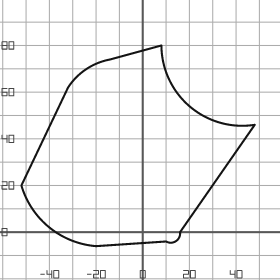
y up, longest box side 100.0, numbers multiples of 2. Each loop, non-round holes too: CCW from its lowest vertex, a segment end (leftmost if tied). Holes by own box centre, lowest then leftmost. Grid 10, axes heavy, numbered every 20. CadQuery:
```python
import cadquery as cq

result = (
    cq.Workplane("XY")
    .moveTo(-20.0, -6.0)
    .lineTo(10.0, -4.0)
    .threePointArc((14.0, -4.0), (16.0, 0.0))
    .lineTo(48.0, 46.0)
    .threePointArc((20.0, 54.0), (8.0, 80.0))
    .lineTo(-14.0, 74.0)
    .threePointArc((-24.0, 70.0), (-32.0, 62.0))
    .lineTo(-52.0, 20.0)
    .threePointArc((-40.0, 2.0), (-20.0, -6.0))
    .close()
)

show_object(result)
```